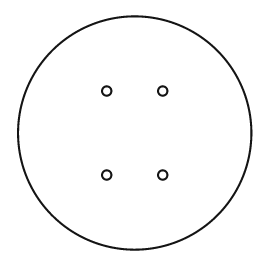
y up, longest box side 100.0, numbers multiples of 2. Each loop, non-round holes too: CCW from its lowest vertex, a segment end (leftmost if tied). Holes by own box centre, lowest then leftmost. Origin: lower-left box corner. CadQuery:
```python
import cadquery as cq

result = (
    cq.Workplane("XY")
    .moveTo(50.0, 50.0)
    .circle(50.0)
    .moveTo(38.0, 32.0)
    .circle(2.0)
    .moveTo(62.0, 32.0)
    .circle(2.0)
    .moveTo(38.0, 68.0)
    .circle(2.0)
    .moveTo(62.0, 68.0)
    .circle(2.0)
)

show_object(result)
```